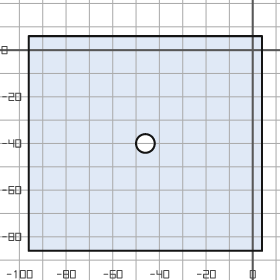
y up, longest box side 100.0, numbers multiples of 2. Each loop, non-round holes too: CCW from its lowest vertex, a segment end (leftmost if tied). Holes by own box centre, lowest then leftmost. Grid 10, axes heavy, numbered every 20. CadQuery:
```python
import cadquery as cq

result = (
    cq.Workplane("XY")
    .moveTo(-96.0, -86.0)
    .lineTo(4.0, -86.0)
    .lineTo(4.0, 6.0)
    .lineTo(-96.0, 6.0)
    .close()
    .moveTo(-46.0, -40.0)
    .circle(4.0)
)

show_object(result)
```